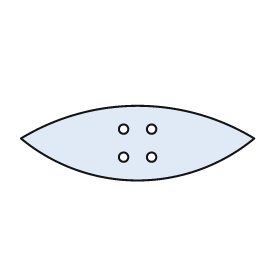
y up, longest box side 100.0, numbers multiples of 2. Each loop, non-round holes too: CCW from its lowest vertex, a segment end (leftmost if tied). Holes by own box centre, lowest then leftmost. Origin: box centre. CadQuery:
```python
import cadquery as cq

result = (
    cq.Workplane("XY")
    .moveTo(-50.0, 2.0)
    .threePointArc((0.0, -16.0), (50.0, 2.0))
    .threePointArc((0.0, 16.0), (-50.0, 2.0))
    .close()
    .moveTo(-6.0, -6.0)
    .circle(2.0)
    .moveTo(6.0, -6.0)
    .circle(2.0)
    .moveTo(-6.0, 6.0)
    .circle(2.0)
    .moveTo(6.0, 6.0)
    .circle(2.0)
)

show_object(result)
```